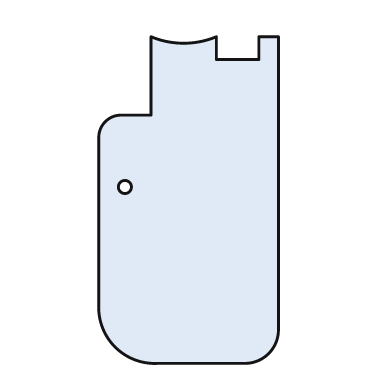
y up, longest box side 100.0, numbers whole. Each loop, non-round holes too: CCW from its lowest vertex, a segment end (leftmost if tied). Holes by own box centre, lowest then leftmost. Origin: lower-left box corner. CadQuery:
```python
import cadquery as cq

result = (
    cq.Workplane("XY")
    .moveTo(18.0, 0.0)
    .lineTo(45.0, 0.0)
    .threePointArc((52.0, 3.0), (55.0, 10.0))
    .lineTo(55.0, 100.0)
    .lineTo(49.0, 100.0)
    .lineTo(49.0, 93.0)
    .lineTo(36.0, 93.0)
    .lineTo(36.0, 100.0)
    .threePointArc((26.0, 98.0), (16.0, 100.0))
    .lineTo(16.0, 76.0)
    .lineTo(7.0, 76.0)
    .threePointArc((2.0, 74.0), (0.0, 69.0))
    .lineTo(0.0, 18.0)
    .threePointArc((5.0, 5.0), (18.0, 0.0))
    .close()
    .moveTo(8.0, 54.0)
    .circle(2.0)
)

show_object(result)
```